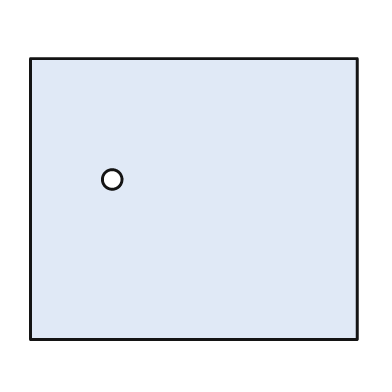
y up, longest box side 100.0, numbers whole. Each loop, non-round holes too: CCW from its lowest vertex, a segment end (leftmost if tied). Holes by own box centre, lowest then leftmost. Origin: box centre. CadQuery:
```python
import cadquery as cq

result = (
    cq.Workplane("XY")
    .moveTo(-50.0, -43.0)
    .lineTo(50.0, -43.0)
    .lineTo(50.0, 43.0)
    .lineTo(-50.0, 43.0)
    .close()
    .moveTo(-25.0, 6.0)
    .circle(3.0)
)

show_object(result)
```